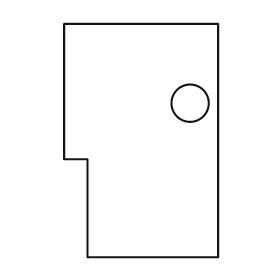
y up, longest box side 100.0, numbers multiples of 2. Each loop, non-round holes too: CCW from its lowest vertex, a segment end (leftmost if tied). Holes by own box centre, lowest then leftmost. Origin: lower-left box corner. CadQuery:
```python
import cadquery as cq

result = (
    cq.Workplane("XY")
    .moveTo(10.0, 0.0)
    .lineTo(66.0, 0.0)
    .lineTo(66.0, 100.0)
    .lineTo(0.0, 100.0)
    .lineTo(0.0, 42.0)
    .lineTo(10.0, 42.0)
    .close()
    .moveTo(54.0, 66.0)
    .circle(8.0)
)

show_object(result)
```